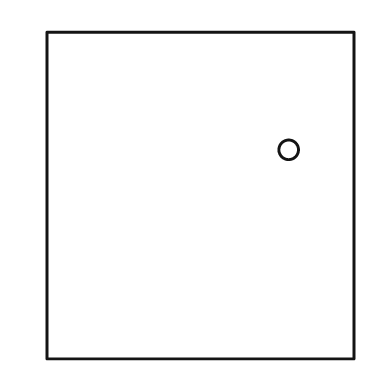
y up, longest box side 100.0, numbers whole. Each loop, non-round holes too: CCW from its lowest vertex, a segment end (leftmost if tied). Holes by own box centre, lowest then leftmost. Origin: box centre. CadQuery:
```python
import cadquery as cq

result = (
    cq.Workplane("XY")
    .moveTo(-47.0, -50.0)
    .lineTo(47.0, -50.0)
    .lineTo(47.0, 50.0)
    .lineTo(-47.0, 50.0)
    .close()
    .moveTo(27.0, 14.0)
    .circle(3.0)
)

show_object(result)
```